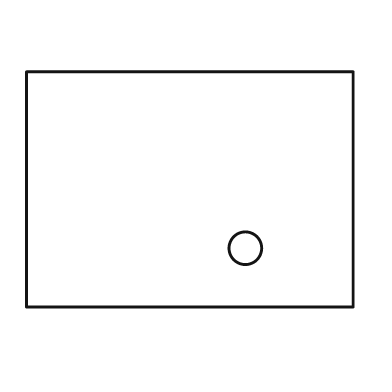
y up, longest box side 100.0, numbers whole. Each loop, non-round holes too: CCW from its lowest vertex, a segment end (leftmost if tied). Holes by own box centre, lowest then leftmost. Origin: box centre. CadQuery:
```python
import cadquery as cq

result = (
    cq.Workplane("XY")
    .moveTo(-50.0, -36.0)
    .lineTo(50.0, -36.0)
    .lineTo(50.0, 36.0)
    .lineTo(-50.0, 36.0)
    .close()
    .moveTo(17.0, -18.0)
    .circle(5.0)
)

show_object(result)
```